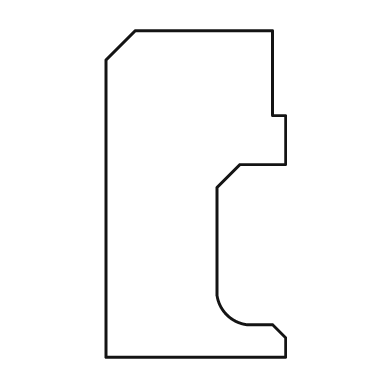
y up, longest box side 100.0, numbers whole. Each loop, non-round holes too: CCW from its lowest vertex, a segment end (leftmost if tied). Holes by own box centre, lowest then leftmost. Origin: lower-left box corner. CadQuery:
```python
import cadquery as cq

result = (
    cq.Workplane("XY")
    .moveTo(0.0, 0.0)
    .lineTo(55.0, 0.0)
    .lineTo(55.0, 6.0)
    .lineTo(51.0, 10.0)
    .lineTo(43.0, 10.0)
    .threePointArc((37.0, 13.0), (34.0, 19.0))
    .lineTo(34.0, 52.0)
    .lineTo(41.0, 59.0)
    .lineTo(55.0, 59.0)
    .lineTo(55.0, 74.0)
    .lineTo(51.0, 74.0)
    .lineTo(51.0, 100.0)
    .lineTo(9.0, 100.0)
    .lineTo(0.0, 91.0)
    .close()
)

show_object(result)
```